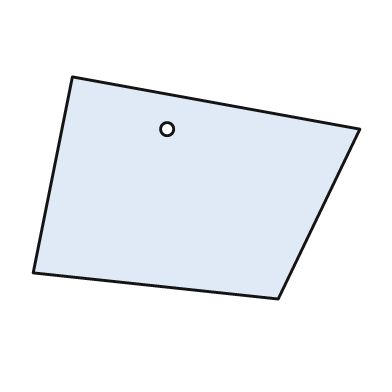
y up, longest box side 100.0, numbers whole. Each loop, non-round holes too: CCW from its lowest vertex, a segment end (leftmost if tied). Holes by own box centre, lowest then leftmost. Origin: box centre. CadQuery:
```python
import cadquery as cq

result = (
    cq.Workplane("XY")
    .moveTo(25.0, -34.0)
    .lineTo(50.0, 18.0)
    .lineTo(-38.0, 34.0)
    .lineTo(-50.0, -26.0)
    .close()
    .moveTo(-9.0, 18.0)
    .circle(2.0)
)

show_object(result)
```